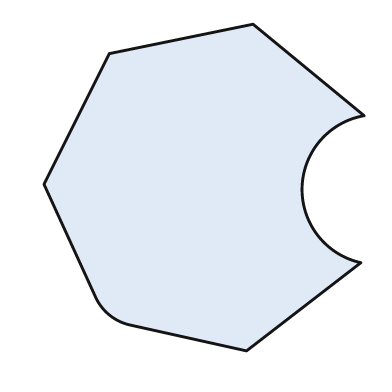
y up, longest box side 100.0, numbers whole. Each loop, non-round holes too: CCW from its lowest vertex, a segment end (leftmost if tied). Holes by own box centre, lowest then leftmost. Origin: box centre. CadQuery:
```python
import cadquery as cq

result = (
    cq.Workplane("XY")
    .moveTo(13.0, -50.0)
    .lineTo(48.0, -23.0)
    .threePointArc((30.0, 0.0), (49.0, 22.0))
    .lineTo(15.0, 50.0)
    .lineTo(-29.0, 41.0)
    .lineTo(-49.0, 1.0)
    .lineTo(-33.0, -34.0)
    .threePointArc((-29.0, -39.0), (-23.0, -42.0))
    .close()
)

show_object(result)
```